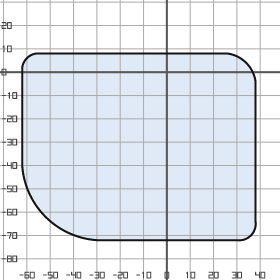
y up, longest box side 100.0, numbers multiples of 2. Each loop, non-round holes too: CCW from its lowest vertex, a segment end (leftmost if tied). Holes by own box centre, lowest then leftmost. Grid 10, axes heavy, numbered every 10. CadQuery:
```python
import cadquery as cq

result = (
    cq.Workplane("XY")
    .moveTo(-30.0, -72.0)
    .lineTo(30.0, -72.0)
    .threePointArc((36.0, -70.0), (38.0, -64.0))
    .lineTo(38.0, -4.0)
    .threePointArc((34.0, 4.0), (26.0, 8.0))
    .lineTo(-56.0, 8.0)
    .threePointArc((-60.0, 6.0), (-62.0, 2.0))
    .lineTo(-62.0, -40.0)
    .threePointArc((-52.0, -62.0), (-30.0, -72.0))
    .close()
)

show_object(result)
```